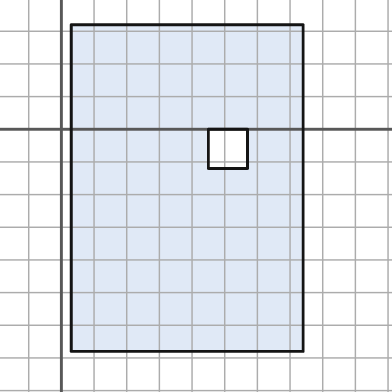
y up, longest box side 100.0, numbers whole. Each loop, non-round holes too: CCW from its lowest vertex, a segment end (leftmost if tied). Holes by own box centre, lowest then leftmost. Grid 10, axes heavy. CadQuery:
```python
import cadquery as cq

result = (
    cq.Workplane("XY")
    .moveTo(3.0, -68.0)
    .lineTo(74.0, -68.0)
    .lineTo(74.0, 32.0)
    .lineTo(3.0, 32.0)
    .close()
    .moveTo(45.0, -12.0)
    .lineTo(57.0, -12.0)
    .lineTo(57.0, 0.0)
    .lineTo(45.0, 0.0)
    .close()
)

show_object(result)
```